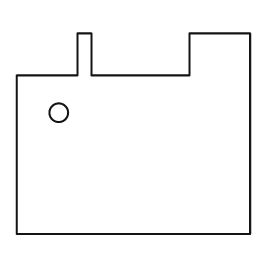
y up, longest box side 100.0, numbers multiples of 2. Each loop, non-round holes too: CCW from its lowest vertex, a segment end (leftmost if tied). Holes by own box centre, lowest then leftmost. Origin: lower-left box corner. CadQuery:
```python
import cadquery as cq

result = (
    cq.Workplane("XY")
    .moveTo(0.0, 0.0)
    .lineTo(100.0, 0.0)
    .lineTo(100.0, 86.0)
    .lineTo(74.0, 86.0)
    .lineTo(74.0, 68.0)
    .lineTo(32.0, 68.0)
    .lineTo(32.0, 86.0)
    .lineTo(26.0, 86.0)
    .lineTo(26.0, 68.0)
    .lineTo(0.0, 68.0)
    .close()
    .moveTo(18.0, 52.0)
    .circle(4.0)
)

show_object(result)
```